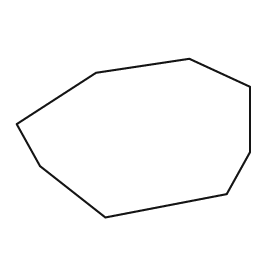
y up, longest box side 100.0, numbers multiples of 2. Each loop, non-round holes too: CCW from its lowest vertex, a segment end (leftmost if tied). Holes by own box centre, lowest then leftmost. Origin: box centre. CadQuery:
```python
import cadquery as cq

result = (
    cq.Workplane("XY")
    .moveTo(-12.0, -34.0)
    .lineTo(40.0, -24.0)
    .lineTo(50.0, -6.0)
    .lineTo(50.0, 22.0)
    .lineTo(24.0, 34.0)
    .lineTo(-16.0, 28.0)
    .lineTo(-50.0, 6.0)
    .lineTo(-40.0, -12.0)
    .close()
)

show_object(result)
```